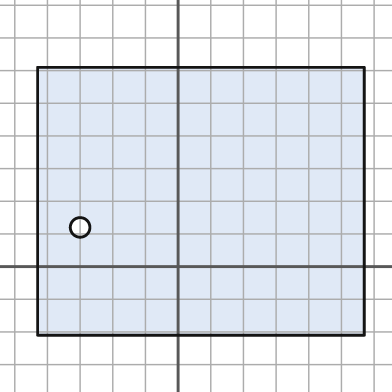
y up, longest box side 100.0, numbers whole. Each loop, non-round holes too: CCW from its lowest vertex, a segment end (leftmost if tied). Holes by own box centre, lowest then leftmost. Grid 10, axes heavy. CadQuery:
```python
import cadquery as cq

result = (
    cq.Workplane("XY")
    .moveTo(-43.0, -21.0)
    .lineTo(57.0, -21.0)
    .lineTo(57.0, 61.0)
    .lineTo(-43.0, 61.0)
    .close()
    .moveTo(-30.0, 12.0)
    .circle(3.0)
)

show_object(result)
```